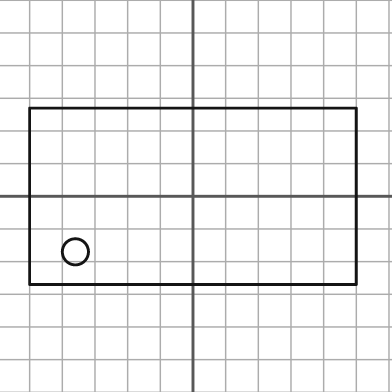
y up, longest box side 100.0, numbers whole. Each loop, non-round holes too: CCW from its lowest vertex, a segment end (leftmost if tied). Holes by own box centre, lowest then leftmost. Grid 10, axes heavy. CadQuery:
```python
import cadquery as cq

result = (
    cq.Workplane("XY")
    .moveTo(-50.0, -27.0)
    .lineTo(50.0, -27.0)
    .lineTo(50.0, 27.0)
    .lineTo(-50.0, 27.0)
    .close()
    .moveTo(-36.0, -17.0)
    .circle(4.0)
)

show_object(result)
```